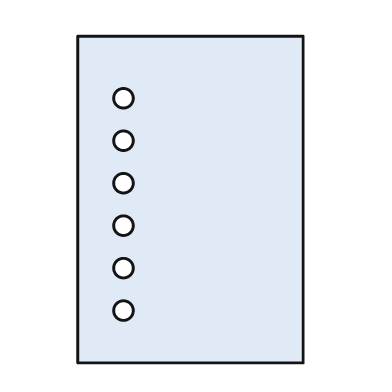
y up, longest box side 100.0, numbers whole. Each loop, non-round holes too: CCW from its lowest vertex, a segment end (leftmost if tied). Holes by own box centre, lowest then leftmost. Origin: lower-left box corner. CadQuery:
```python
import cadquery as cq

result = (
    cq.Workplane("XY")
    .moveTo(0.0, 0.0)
    .lineTo(69.0, 0.0)
    .lineTo(69.0, 100.0)
    .lineTo(0.0, 100.0)
    .close()
    .moveTo(14.0, 16.0)
    .circle(3.0)
    .moveTo(14.0, 29.0)
    .circle(3.0)
    .moveTo(14.0, 42.0)
    .circle(3.0)
    .moveTo(14.0, 55.0)
    .circle(3.0)
    .moveTo(14.0, 68.0)
    .circle(3.0)
    .moveTo(14.0, 81.0)
    .circle(3.0)
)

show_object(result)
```